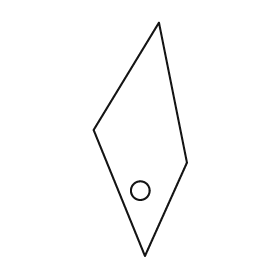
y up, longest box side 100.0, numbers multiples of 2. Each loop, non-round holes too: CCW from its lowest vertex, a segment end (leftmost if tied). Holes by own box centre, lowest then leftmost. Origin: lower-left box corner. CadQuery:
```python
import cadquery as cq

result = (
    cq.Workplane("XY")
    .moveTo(22.0, 0.0)
    .lineTo(40.0, 40.0)
    .lineTo(28.0, 100.0)
    .lineTo(0.0, 54.0)
    .close()
    .moveTo(20.0, 28.0)
    .circle(4.0)
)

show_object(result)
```